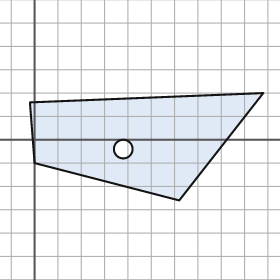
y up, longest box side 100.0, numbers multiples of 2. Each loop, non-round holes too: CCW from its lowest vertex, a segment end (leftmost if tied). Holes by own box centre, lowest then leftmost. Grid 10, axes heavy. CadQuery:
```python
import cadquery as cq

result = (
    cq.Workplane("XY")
    .moveTo(62.0, -26.0)
    .lineTo(98.0, 20.0)
    .lineTo(-2.0, 16.0)
    .lineTo(0.0, -10.0)
    .close()
    .moveTo(38.0, -4.0)
    .circle(4.0)
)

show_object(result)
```